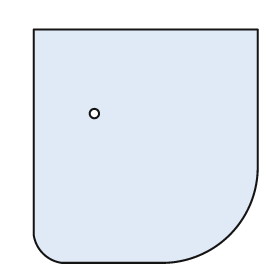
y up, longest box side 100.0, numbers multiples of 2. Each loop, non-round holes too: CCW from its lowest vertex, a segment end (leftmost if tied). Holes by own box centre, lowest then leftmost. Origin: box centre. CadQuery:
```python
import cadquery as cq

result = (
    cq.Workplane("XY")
    .moveTo(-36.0, -50.0)
    .lineTo(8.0, -50.0)
    .threePointArc((36.0, -38.0), (48.0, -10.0))
    .lineTo(48.0, 50.0)
    .lineTo(-48.0, 50.0)
    .lineTo(-48.0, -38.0)
    .threePointArc((-44.0, -46.0), (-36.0, -50.0))
    .close()
    .moveTo(-22.0, 14.0)
    .circle(2.0)
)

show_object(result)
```